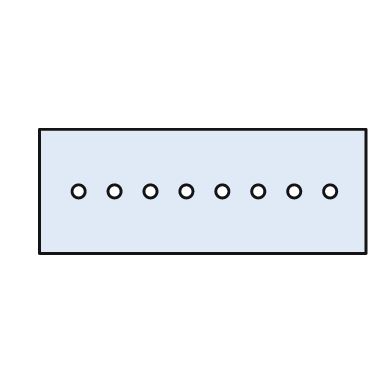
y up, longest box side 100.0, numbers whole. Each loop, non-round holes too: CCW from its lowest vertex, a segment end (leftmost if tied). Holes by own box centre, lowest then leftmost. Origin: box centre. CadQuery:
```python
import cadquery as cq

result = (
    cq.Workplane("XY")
    .moveTo(-50.0, -19.0)
    .lineTo(50.0, -19.0)
    .lineTo(50.0, 19.0)
    .lineTo(-50.0, 19.0)
    .close()
    .moveTo(-38.0, 0.0)
    .circle(2.0)
    .moveTo(-27.0, 0.0)
    .circle(2.0)
    .moveTo(-16.0, 0.0)
    .circle(2.0)
    .moveTo(-5.0, 0.0)
    .circle(2.0)
    .moveTo(6.0, 0.0)
    .circle(2.0)
    .moveTo(17.0, 0.0)
    .circle(2.0)
    .moveTo(28.0, 0.0)
    .circle(2.0)
    .moveTo(39.0, 0.0)
    .circle(2.0)
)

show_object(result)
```